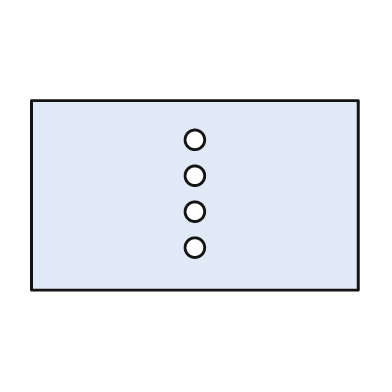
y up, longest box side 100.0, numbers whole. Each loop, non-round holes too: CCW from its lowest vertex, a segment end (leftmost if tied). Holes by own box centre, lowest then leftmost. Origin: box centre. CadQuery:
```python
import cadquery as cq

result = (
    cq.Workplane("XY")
    .moveTo(-50.0, -29.0)
    .lineTo(50.0, -29.0)
    .lineTo(50.0, 29.0)
    .lineTo(-50.0, 29.0)
    .close()
    .moveTo(0.0, -16.0)
    .circle(3.0)
    .moveTo(0.0, -5.0)
    .circle(3.0)
    .moveTo(0.0, 6.0)
    .circle(3.0)
    .moveTo(0.0, 17.0)
    .circle(3.0)
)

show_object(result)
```